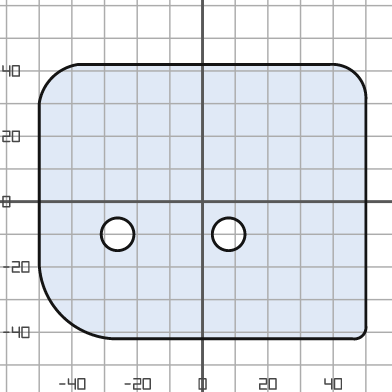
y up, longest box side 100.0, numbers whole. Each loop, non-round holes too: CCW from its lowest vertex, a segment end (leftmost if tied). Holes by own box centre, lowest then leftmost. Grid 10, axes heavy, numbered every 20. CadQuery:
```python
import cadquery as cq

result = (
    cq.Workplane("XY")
    .moveTo(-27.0, -42.0)
    .lineTo(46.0, -42.0)
    .threePointArc((49.0, -41.0), (50.0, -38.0))
    .lineTo(50.0, 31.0)
    .threePointArc((47.0, 39.0), (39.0, 42.0))
    .lineTo(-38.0, 42.0)
    .threePointArc((-46.0, 38.0), (-50.0, 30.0))
    .lineTo(-50.0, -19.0)
    .threePointArc((-43.0, -35.0), (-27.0, -42.0))
    .close()
    .moveTo(-26.0, -10.0)
    .circle(5.0)
    .moveTo(8.0, -10.0)
    .circle(5.0)
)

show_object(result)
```